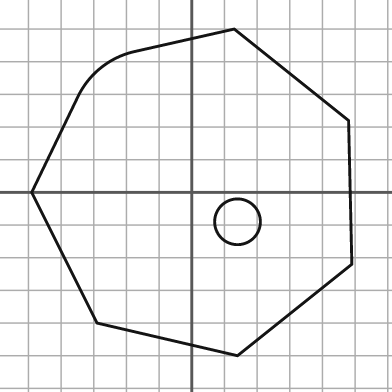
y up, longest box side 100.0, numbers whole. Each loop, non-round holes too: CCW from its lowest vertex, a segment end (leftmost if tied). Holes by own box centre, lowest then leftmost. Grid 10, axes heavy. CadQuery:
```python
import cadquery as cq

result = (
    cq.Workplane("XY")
    .moveTo(14.0, -50.0)
    .lineTo(49.0, -22.0)
    .lineTo(48.0, 22.0)
    .lineTo(13.0, 50.0)
    .lineTo(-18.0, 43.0)
    .threePointArc((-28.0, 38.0), (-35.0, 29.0))
    .lineTo(-49.0, 0.0)
    .lineTo(-29.0, -40.0)
    .close()
    .moveTo(14.0, -9.0)
    .circle(7.0)
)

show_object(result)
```